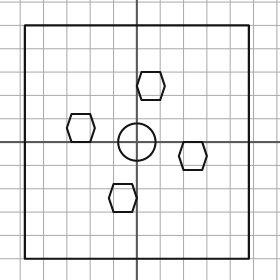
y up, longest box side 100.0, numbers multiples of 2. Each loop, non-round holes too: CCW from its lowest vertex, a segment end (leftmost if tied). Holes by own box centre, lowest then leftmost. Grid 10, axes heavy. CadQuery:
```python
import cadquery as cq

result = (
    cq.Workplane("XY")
    .moveTo(-48.0, -50.0)
    .lineTo(48.0, -50.0)
    .lineTo(48.0, 50.0)
    .lineTo(-48.0, 50.0)
    .close()
    .moveTo(-10.0, -30.0)
    .lineTo(-2.0, -30.0)
    .lineTo(0.0, -24.0)
    .lineTo(-2.0, -18.0)
    .lineTo(-10.0, -18.0)
    .lineTo(-12.0, -24.0)
    .close()
    .moveTo(20.0, -12.0)
    .lineTo(28.0, -12.0)
    .lineTo(30.0, -6.0)
    .lineTo(28.0, 0.0)
    .lineTo(20.0, 0.0)
    .lineTo(18.0, -6.0)
    .close()
    .moveTo(0.0, 0.0)
    .circle(8.0)
    .moveTo(-28.0, 0.0)
    .lineTo(-20.0, 0.0)
    .lineTo(-18.0, 6.0)
    .lineTo(-20.0, 12.0)
    .lineTo(-28.0, 12.0)
    .lineTo(-30.0, 6.0)
    .close()
    .moveTo(2.0, 18.0)
    .lineTo(10.0, 18.0)
    .lineTo(12.0, 24.0)
    .lineTo(10.0, 30.0)
    .lineTo(2.0, 30.0)
    .lineTo(0.0, 24.0)
    .close()
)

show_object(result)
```